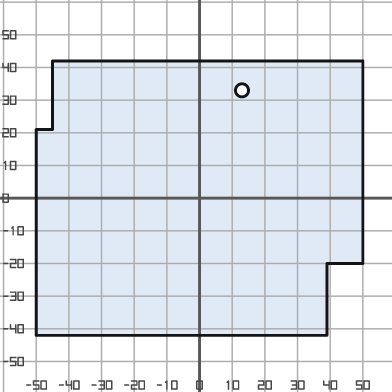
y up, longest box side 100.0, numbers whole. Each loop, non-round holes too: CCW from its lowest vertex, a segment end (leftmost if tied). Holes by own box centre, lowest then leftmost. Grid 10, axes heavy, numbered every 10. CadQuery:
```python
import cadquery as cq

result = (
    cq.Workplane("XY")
    .moveTo(-50.0, -42.0)
    .lineTo(39.0, -42.0)
    .lineTo(39.0, -20.0)
    .lineTo(50.0, -20.0)
    .lineTo(50.0, 42.0)
    .lineTo(-45.0, 42.0)
    .lineTo(-45.0, 21.0)
    .lineTo(-50.0, 21.0)
    .close()
    .moveTo(13.0, 33.0)
    .circle(2.0)
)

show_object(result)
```